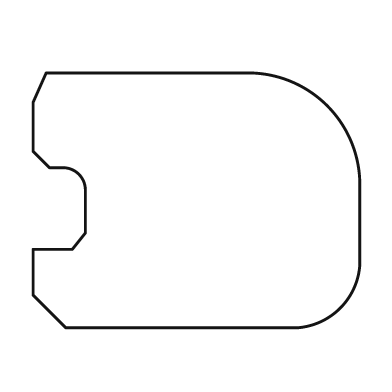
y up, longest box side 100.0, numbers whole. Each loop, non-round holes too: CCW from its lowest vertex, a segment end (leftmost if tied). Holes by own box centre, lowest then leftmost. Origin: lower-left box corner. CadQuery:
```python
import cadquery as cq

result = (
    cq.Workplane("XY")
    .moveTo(10.0, 0.0)
    .lineTo(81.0, 0.0)
    .threePointArc((94.0, 6.0), (100.0, 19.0))
    .lineTo(100.0, 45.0)
    .threePointArc((90.0, 68.0), (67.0, 78.0))
    .lineTo(4.0, 78.0)
    .lineTo(0.0, 69.0)
    .lineTo(0.0, 54.0)
    .lineTo(5.0, 49.0)
    .lineTo(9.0, 49.0)
    .threePointArc((14.0, 47.0), (16.0, 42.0))
    .lineTo(16.0, 29.0)
    .lineTo(12.0, 24.0)
    .lineTo(0.0, 24.0)
    .lineTo(0.0, 10.0)
    .close()
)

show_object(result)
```